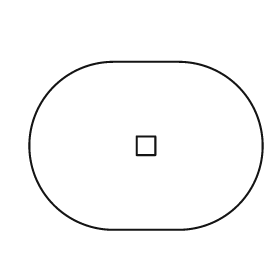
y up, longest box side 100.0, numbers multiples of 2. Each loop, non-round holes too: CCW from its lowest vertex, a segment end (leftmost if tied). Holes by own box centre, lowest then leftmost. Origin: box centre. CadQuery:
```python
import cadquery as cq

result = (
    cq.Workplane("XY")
    .moveTo(-14.0, -36.0)
    .lineTo(14.0, -36.0)
    .threePointArc((50.0, 0.0), (14.0, 36.0))
    .lineTo(-14.0, 36.0)
    .threePointArc((-50.0, 0.0), (-14.0, -36.0))
    .close()
    .moveTo(-4.0, -4.0)
    .lineTo(4.0, -4.0)
    .lineTo(4.0, 4.0)
    .lineTo(-4.0, 4.0)
    .close()
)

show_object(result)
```